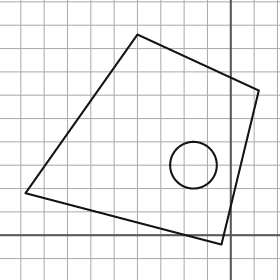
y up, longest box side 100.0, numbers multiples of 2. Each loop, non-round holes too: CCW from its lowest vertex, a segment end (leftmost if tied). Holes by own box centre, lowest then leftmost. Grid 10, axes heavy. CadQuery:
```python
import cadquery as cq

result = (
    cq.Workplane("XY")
    .moveTo(-4.0, -4.0)
    .lineTo(12.0, 62.0)
    .lineTo(-40.0, 86.0)
    .lineTo(-88.0, 18.0)
    .close()
    .moveTo(-16.0, 30.0)
    .circle(10.0)
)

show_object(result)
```